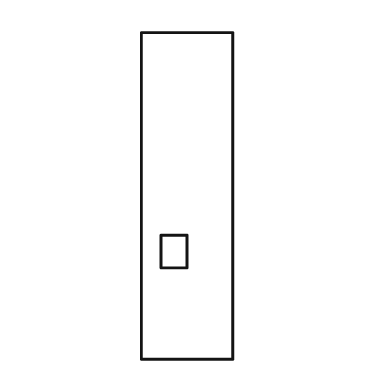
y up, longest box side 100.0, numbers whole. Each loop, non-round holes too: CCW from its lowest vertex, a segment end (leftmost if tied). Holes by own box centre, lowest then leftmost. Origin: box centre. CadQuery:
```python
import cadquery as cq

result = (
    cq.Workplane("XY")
    .moveTo(-14.0, -50.0)
    .lineTo(14.0, -50.0)
    .lineTo(14.0, 50.0)
    .lineTo(-14.0, 50.0)
    .close()
    .moveTo(-8.0, -22.0)
    .lineTo(0.0, -22.0)
    .lineTo(0.0, -12.0)
    .lineTo(-8.0, -12.0)
    .close()
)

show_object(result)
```